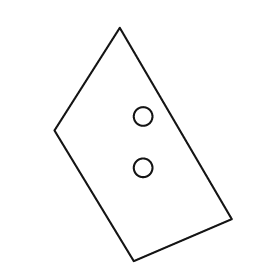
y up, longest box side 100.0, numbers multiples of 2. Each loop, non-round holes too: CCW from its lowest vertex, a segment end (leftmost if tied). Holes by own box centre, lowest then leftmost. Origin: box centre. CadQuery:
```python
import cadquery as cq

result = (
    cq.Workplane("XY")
    .moveTo(-4.0, -50.0)
    .lineTo(38.0, -32.0)
    .lineTo(-10.0, 50.0)
    .lineTo(-38.0, 6.0)
    .close()
    .moveTo(0.0, -10.0)
    .circle(4.0)
    .moveTo(0.0, 12.0)
    .circle(4.0)
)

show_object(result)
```